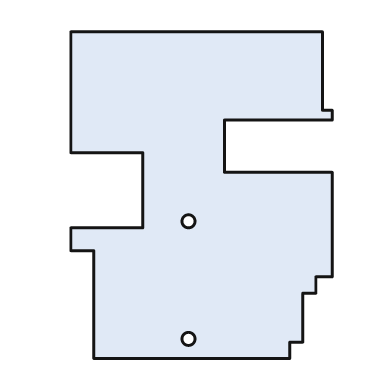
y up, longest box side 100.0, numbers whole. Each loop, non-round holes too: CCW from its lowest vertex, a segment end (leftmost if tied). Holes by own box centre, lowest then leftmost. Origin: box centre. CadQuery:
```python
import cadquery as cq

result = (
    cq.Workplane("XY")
    .moveTo(-33.0, -50.0)
    .lineTo(27.0, -50.0)
    .lineTo(27.0, -45.0)
    .lineTo(31.0, -45.0)
    .lineTo(31.0, -30.0)
    .lineTo(35.0, -30.0)
    .lineTo(35.0, -25.0)
    .lineTo(40.0, -25.0)
    .lineTo(40.0, 7.0)
    .lineTo(7.0, 7.0)
    .lineTo(7.0, 23.0)
    .lineTo(40.0, 23.0)
    .lineTo(40.0, 26.0)
    .lineTo(37.0, 26.0)
    .lineTo(37.0, 50.0)
    .lineTo(-40.0, 50.0)
    .lineTo(-40.0, 13.0)
    .lineTo(-18.0, 13.0)
    .lineTo(-18.0, -10.0)
    .lineTo(-40.0, -10.0)
    .lineTo(-40.0, -17.0)
    .lineTo(-33.0, -17.0)
    .close()
    .moveTo(-4.0, -44.0)
    .circle(2.0)
    .moveTo(-4.0, -8.0)
    .circle(2.0)
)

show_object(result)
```